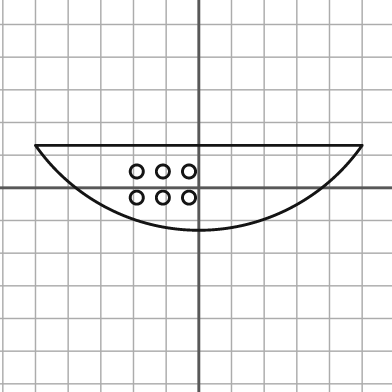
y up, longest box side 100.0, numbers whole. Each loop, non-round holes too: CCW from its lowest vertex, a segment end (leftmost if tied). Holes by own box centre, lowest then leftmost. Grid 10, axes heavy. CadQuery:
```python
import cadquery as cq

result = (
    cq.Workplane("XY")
    .moveTo(-50.0, 13.0)
    .threePointArc((0.0, -13.0), (50.0, 13.0))
    .close()
    .moveTo(-19.0, -3.0)
    .circle(2.0)
    .moveTo(-11.0, -3.0)
    .circle(2.0)
    .moveTo(-3.0, -3.0)
    .circle(2.0)
    .moveTo(-19.0, 5.0)
    .circle(2.0)
    .moveTo(-11.0, 5.0)
    .circle(2.0)
    .moveTo(-3.0, 5.0)
    .circle(2.0)
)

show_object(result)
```